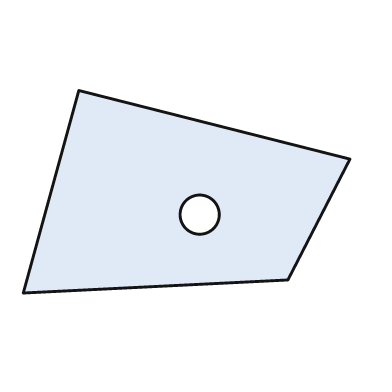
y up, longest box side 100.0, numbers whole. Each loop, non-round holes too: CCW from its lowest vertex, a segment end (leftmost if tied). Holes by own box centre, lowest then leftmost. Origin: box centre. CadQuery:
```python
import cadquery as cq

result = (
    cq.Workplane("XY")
    .moveTo(-50.0, -31.0)
    .lineTo(31.0, -27.0)
    .lineTo(50.0, 10.0)
    .lineTo(-33.0, 31.0)
    .close()
    .moveTo(4.0, -7.0)
    .circle(6.0)
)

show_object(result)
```